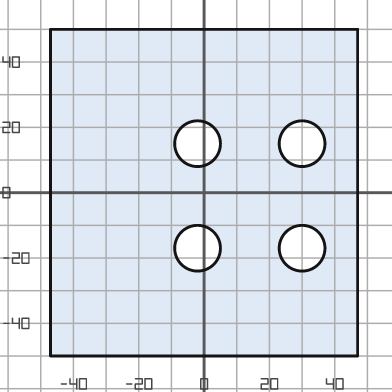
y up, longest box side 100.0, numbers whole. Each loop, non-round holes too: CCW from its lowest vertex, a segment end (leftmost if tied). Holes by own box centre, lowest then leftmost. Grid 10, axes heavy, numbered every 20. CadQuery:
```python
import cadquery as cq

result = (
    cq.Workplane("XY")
    .moveTo(-47.0, -50.0)
    .lineTo(47.0, -50.0)
    .lineTo(47.0, 50.0)
    .lineTo(-47.0, 50.0)
    .close()
    .moveTo(-2.0, -17.0)
    .circle(7.0)
    .moveTo(30.0, -17.0)
    .circle(7.0)
    .moveTo(-2.0, 15.0)
    .circle(7.0)
    .moveTo(30.0, 15.0)
    .circle(7.0)
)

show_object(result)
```